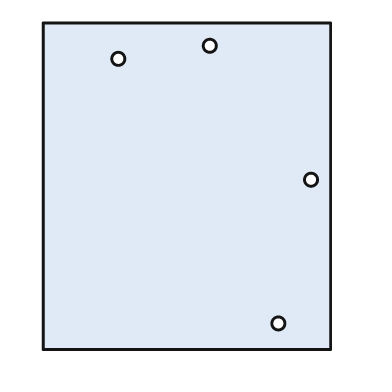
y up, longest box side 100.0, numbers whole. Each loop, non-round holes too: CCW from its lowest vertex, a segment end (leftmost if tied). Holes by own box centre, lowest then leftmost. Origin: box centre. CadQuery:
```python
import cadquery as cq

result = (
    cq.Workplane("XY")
    .moveTo(-44.0, -50.0)
    .lineTo(44.0, -50.0)
    .lineTo(44.0, 50.0)
    .lineTo(-44.0, 50.0)
    .close()
    .moveTo(28.0, -42.0)
    .circle(2.0)
    .moveTo(38.0, 2.0)
    .circle(2.0)
    .moveTo(-21.0, 39.0)
    .circle(2.0)
    .moveTo(7.0, 43.0)
    .circle(2.0)
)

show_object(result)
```